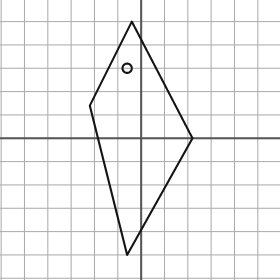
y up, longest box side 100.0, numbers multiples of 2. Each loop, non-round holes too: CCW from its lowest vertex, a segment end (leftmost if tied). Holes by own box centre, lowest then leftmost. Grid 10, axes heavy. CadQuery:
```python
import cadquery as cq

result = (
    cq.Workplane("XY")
    .moveTo(-6.0, -50.0)
    .lineTo(22.0, 0.0)
    .lineTo(-4.0, 50.0)
    .lineTo(-22.0, 14.0)
    .close()
    .moveTo(-6.0, 30.0)
    .circle(2.0)
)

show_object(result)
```